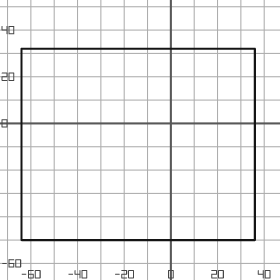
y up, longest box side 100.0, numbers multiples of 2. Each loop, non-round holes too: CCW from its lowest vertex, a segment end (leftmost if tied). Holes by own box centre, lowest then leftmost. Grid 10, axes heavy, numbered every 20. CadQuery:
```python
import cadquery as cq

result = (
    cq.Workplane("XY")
    .moveTo(-64.0, -50.0)
    .lineTo(36.0, -50.0)
    .lineTo(36.0, 32.0)
    .lineTo(-64.0, 32.0)
    .close()
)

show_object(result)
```